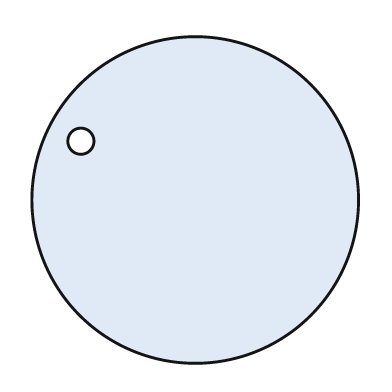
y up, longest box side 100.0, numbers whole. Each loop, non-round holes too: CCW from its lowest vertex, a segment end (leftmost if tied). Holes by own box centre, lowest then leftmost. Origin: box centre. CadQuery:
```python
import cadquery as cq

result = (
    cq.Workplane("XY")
    .moveTo(0.0, 0.0)
    .circle(50.0)
    .moveTo(-35.0, 18.0)
    .circle(4.0)
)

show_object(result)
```